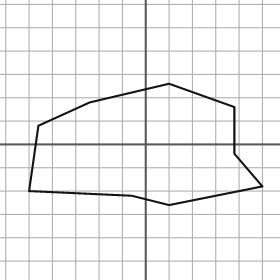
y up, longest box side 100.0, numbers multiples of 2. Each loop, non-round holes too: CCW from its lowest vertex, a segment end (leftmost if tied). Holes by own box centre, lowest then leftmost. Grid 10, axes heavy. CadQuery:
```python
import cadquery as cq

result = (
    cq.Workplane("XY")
    .moveTo(10.0, -26.0)
    .lineTo(50.0, -18.0)
    .lineTo(38.0, -4.0)
    .lineTo(38.0, 16.0)
    .lineTo(10.0, 26.0)
    .lineTo(-24.0, 18.0)
    .lineTo(-46.0, 8.0)
    .lineTo(-50.0, -20.0)
    .lineTo(-6.0, -22.0)
    .close()
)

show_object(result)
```